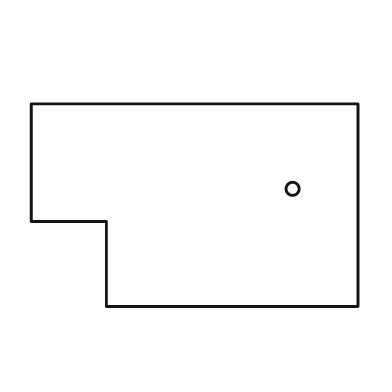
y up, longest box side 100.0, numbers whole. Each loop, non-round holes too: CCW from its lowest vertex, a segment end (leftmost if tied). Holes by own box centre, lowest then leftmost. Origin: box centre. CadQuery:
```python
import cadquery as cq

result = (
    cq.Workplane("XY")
    .moveTo(-27.0, -31.0)
    .lineTo(50.0, -31.0)
    .lineTo(50.0, 31.0)
    .lineTo(-50.0, 31.0)
    .lineTo(-50.0, -5.0)
    .lineTo(-27.0, -5.0)
    .close()
    .moveTo(30.0, 5.0)
    .circle(2.0)
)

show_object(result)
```